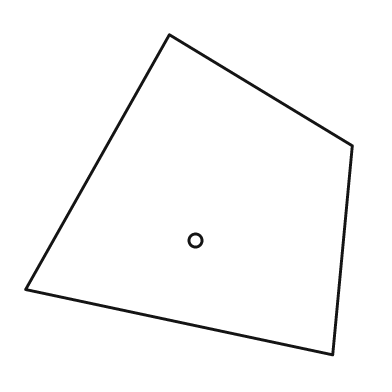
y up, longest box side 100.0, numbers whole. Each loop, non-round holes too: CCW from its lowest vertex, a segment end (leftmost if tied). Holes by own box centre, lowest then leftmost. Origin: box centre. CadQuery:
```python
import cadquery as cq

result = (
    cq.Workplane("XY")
    .moveTo(44.0, -49.0)
    .lineTo(50.0, 15.0)
    .lineTo(-6.0, 49.0)
    .lineTo(-50.0, -29.0)
    .close()
    .moveTo(2.0, -14.0)
    .circle(2.0)
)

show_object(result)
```